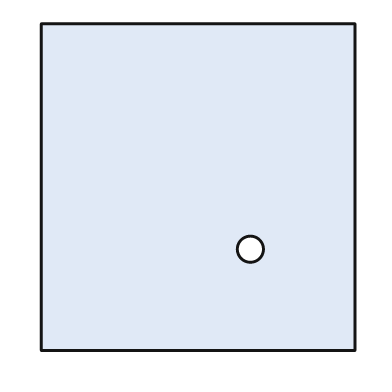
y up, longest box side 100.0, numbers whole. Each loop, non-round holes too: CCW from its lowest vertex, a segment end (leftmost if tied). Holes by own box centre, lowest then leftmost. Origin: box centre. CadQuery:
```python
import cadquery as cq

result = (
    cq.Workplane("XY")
    .moveTo(-48.0, -50.0)
    .lineTo(48.0, -50.0)
    .lineTo(48.0, 50.0)
    .lineTo(-48.0, 50.0)
    .close()
    .moveTo(16.0, -19.0)
    .circle(4.0)
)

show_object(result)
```